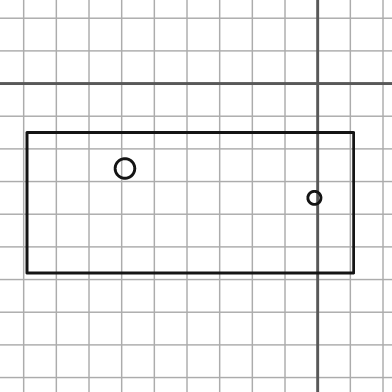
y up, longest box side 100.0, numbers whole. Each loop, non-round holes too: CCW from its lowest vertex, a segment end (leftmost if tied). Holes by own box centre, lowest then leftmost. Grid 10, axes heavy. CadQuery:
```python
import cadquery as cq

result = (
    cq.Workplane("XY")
    .moveTo(-89.0, -58.0)
    .lineTo(11.0, -58.0)
    .lineTo(11.0, -15.0)
    .lineTo(-89.0, -15.0)
    .close()
    .moveTo(-1.0, -35.0)
    .circle(2.0)
    .moveTo(-59.0, -26.0)
    .circle(3.0)
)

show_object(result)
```